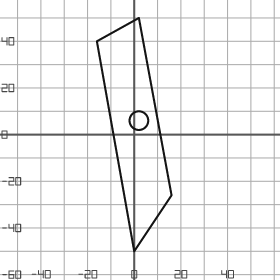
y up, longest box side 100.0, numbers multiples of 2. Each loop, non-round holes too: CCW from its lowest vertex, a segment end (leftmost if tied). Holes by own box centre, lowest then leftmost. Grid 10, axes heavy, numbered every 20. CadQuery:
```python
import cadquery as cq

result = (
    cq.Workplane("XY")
    .moveTo(0.0, -50.0)
    .lineTo(16.0, -26.0)
    .lineTo(2.0, 50.0)
    .lineTo(-16.0, 40.0)
    .close()
    .moveTo(2.0, 6.0)
    .circle(4.0)
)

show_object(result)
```